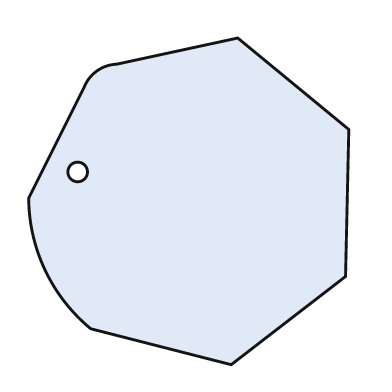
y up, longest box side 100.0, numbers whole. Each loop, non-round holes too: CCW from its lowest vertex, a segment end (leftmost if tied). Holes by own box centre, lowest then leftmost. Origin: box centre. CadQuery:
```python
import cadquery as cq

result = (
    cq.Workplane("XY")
    .moveTo(13.0, -50.0)
    .lineTo(48.0, -23.0)
    .lineTo(49.0, 22.0)
    .lineTo(15.0, 50.0)
    .lineTo(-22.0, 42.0)
    .threePointArc((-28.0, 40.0), (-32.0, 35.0))
    .lineTo(-49.0, 1.0)
    .threePointArc((-44.0, -21.0), (-30.0, -39.0))
    .close()
    .moveTo(-34.0, 9.0)
    .circle(3.0)
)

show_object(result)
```